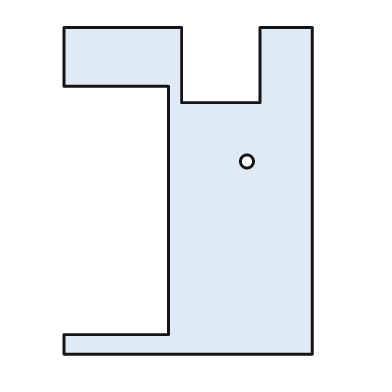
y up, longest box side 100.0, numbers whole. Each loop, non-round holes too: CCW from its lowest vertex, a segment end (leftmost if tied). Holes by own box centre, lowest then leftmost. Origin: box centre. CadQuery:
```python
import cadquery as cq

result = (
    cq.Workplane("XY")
    .moveTo(-38.0, -50.0)
    .lineTo(38.0, -50.0)
    .lineTo(38.0, 50.0)
    .lineTo(22.0, 50.0)
    .lineTo(22.0, 27.0)
    .lineTo(-2.0, 27.0)
    .lineTo(-2.0, 50.0)
    .lineTo(-38.0, 50.0)
    .lineTo(-38.0, 32.0)
    .lineTo(-6.0, 32.0)
    .lineTo(-6.0, -44.0)
    .lineTo(-38.0, -44.0)
    .close()
    .moveTo(18.0, 9.0)
    .circle(2.0)
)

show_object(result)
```